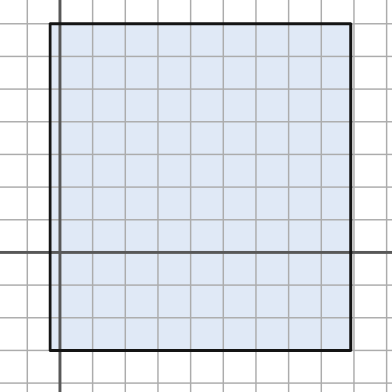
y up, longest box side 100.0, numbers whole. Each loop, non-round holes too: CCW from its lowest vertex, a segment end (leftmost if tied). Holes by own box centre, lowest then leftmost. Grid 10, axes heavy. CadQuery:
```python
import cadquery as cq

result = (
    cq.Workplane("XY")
    .moveTo(-3.0, -30.0)
    .lineTo(89.0, -30.0)
    .lineTo(89.0, 70.0)
    .lineTo(-3.0, 70.0)
    .close()
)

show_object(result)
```